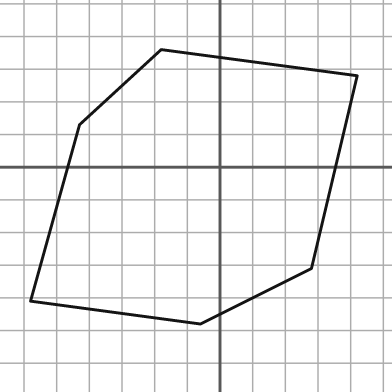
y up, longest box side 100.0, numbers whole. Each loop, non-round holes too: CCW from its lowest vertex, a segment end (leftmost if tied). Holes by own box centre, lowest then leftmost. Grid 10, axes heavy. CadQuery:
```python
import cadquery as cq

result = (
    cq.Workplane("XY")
    .moveTo(-6.0, -48.0)
    .lineTo(28.0, -31.0)
    .lineTo(42.0, 28.0)
    .lineTo(-18.0, 36.0)
    .lineTo(-43.0, 13.0)
    .lineTo(-58.0, -41.0)
    .close()
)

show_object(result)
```